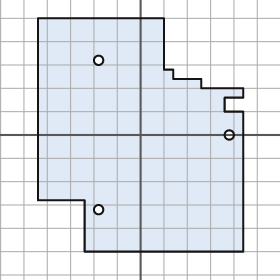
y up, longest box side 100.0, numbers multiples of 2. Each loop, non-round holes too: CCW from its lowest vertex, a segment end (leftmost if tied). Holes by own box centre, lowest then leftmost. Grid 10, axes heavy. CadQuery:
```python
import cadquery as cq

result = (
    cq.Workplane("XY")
    .moveTo(-24.0, -50.0)
    .lineTo(44.0, -50.0)
    .lineTo(44.0, 10.0)
    .lineTo(36.0, 10.0)
    .lineTo(36.0, 16.0)
    .lineTo(44.0, 16.0)
    .lineTo(44.0, 20.0)
    .lineTo(26.0, 20.0)
    .lineTo(26.0, 24.0)
    .lineTo(14.0, 24.0)
    .lineTo(14.0, 28.0)
    .lineTo(10.0, 28.0)
    .lineTo(10.0, 50.0)
    .lineTo(-44.0, 50.0)
    .lineTo(-44.0, -28.0)
    .lineTo(-24.0, -28.0)
    .close()
    .moveTo(-18.0, -32.0)
    .circle(2.0)
    .moveTo(38.0, 0.0)
    .circle(2.0)
    .moveTo(-18.0, 32.0)
    .circle(2.0)
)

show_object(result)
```